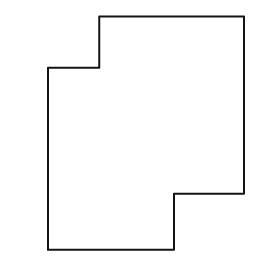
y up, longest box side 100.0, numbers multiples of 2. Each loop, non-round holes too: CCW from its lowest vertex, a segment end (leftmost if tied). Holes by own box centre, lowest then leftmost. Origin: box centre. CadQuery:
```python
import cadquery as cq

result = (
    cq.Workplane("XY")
    .moveTo(-42.0, -50.0)
    .lineTo(12.0, -50.0)
    .lineTo(12.0, -26.0)
    .lineTo(42.0, -26.0)
    .lineTo(42.0, 50.0)
    .lineTo(-20.0, 50.0)
    .lineTo(-20.0, 28.0)
    .lineTo(-42.0, 28.0)
    .close()
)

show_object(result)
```